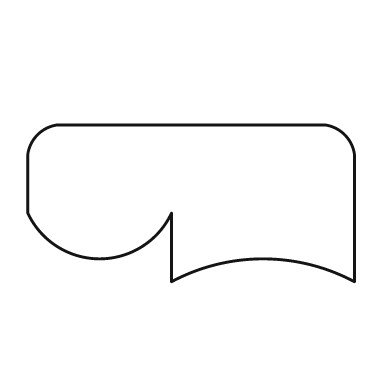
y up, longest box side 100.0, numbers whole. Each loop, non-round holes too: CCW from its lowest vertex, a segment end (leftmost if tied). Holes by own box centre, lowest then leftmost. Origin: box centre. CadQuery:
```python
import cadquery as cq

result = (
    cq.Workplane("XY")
    .moveTo(-6.0, -24.0)
    .threePointArc((22.0, -17.0), (50.0, -24.0))
    .lineTo(50.0, 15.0)
    .threePointArc((47.0, 21.0), (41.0, 24.0))
    .lineTo(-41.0, 24.0)
    .threePointArc((-47.0, 21.0), (-50.0, 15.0))
    .lineTo(-50.0, -3.0)
    .threePointArc((-28.0, -17.0), (-6.0, -3.0))
    .close()
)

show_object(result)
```